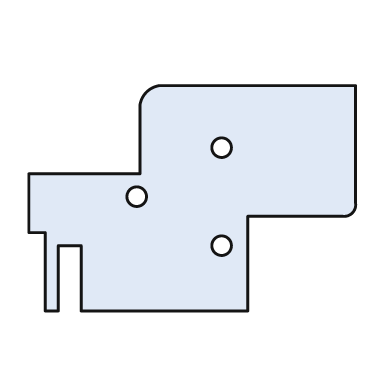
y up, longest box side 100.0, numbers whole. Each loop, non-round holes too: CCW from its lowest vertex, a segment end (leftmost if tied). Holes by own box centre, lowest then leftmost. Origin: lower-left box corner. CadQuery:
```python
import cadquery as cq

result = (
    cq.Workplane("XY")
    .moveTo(5.0, 0.0)
    .lineTo(9.0, 0.0)
    .lineTo(9.0, 20.0)
    .lineTo(16.0, 20.0)
    .lineTo(16.0, 0.0)
    .lineTo(67.0, 0.0)
    .lineTo(67.0, 29.0)
    .lineTo(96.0, 29.0)
    .threePointArc((99.0, 30.0), (100.0, 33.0))
    .lineTo(100.0, 69.0)
    .lineTo(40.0, 69.0)
    .threePointArc((36.0, 67.0), (34.0, 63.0))
    .lineTo(34.0, 42.0)
    .lineTo(0.0, 42.0)
    .lineTo(0.0, 24.0)
    .lineTo(5.0, 24.0)
    .close()
    .moveTo(59.0, 20.0)
    .circle(3.0)
    .moveTo(33.0, 35.0)
    .circle(3.0)
    .moveTo(59.0, 50.0)
    .circle(3.0)
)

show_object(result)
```